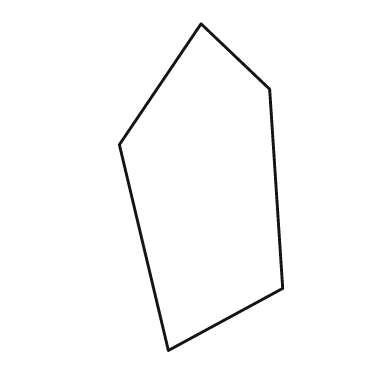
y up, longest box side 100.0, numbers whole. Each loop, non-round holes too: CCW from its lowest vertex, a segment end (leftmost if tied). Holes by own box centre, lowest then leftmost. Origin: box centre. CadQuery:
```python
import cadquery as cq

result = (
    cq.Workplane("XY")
    .moveTo(-10.0, -50.0)
    .lineTo(25.0, -31.0)
    .lineTo(21.0, 30.0)
    .lineTo(0.0, 50.0)
    .lineTo(-25.0, 13.0)
    .close()
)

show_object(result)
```